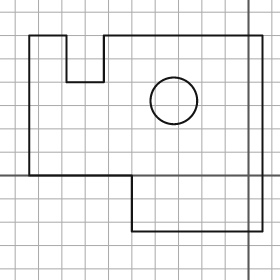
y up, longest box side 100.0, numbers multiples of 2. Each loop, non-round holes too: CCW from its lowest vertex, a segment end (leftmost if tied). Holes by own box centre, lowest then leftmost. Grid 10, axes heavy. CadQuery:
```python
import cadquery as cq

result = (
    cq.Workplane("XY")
    .moveTo(-50.0, -24.0)
    .lineTo(6.0, -24.0)
    .lineTo(6.0, 60.0)
    .lineTo(-62.0, 60.0)
    .lineTo(-62.0, 40.0)
    .lineTo(-78.0, 40.0)
    .lineTo(-78.0, 60.0)
    .lineTo(-94.0, 60.0)
    .lineTo(-94.0, 0.0)
    .lineTo(-50.0, 0.0)
    .close()
    .moveTo(-32.0, 32.0)
    .circle(10.0)
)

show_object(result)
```